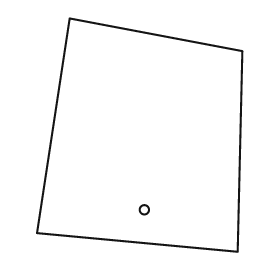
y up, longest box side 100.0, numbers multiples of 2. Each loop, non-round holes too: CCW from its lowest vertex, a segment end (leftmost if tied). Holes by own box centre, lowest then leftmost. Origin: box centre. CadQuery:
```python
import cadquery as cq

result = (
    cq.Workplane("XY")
    .moveTo(42.0, -50.0)
    .lineTo(44.0, 36.0)
    .lineTo(-30.0, 50.0)
    .lineTo(-44.0, -42.0)
    .close()
    .moveTo(2.0, -32.0)
    .circle(2.0)
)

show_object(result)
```